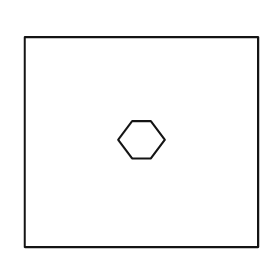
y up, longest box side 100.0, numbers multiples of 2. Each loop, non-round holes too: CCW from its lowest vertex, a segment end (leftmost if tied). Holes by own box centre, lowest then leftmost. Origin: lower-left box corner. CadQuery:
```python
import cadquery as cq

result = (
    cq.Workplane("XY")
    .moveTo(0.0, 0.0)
    .lineTo(100.0, 0.0)
    .lineTo(100.0, 90.0)
    .lineTo(0.0, 90.0)
    .close()
    .moveTo(46.0, 38.0)
    .lineTo(54.0, 38.0)
    .lineTo(60.0, 46.0)
    .lineTo(54.0, 54.0)
    .lineTo(46.0, 54.0)
    .lineTo(40.0, 46.0)
    .close()
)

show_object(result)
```